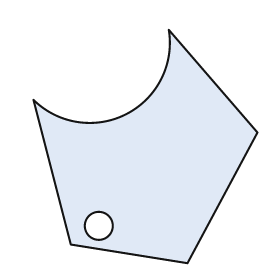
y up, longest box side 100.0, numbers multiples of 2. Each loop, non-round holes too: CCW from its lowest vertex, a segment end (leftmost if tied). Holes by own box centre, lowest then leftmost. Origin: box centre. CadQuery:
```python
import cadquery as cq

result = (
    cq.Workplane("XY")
    .moveTo(18.0, -50.0)
    .lineTo(48.0, 6.0)
    .lineTo(10.0, 50.0)
    .threePointArc((-8.0, 14.0), (-48.0, 20.0))
    .lineTo(-32.0, -42.0)
    .close()
    .moveTo(-20.0, -34.0)
    .circle(6.0)
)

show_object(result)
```